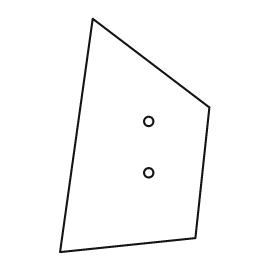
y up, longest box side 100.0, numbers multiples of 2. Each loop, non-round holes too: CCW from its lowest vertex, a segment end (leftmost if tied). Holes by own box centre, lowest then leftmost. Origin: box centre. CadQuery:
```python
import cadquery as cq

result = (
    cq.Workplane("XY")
    .moveTo(-32.0, -50.0)
    .lineTo(26.0, -44.0)
    .lineTo(32.0, 12.0)
    .lineTo(-18.0, 50.0)
    .close()
    .moveTo(6.0, -16.0)
    .circle(2.0)
    .moveTo(6.0, 6.0)
    .circle(2.0)
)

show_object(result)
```